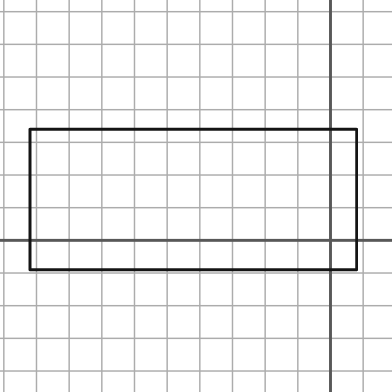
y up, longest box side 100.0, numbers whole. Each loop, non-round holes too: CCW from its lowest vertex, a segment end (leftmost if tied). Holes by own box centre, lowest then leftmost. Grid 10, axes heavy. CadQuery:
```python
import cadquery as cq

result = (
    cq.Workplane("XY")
    .moveTo(-92.0, -9.0)
    .lineTo(8.0, -9.0)
    .lineTo(8.0, 34.0)
    .lineTo(-92.0, 34.0)
    .close()
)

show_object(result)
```